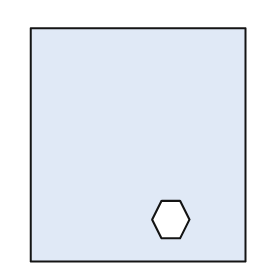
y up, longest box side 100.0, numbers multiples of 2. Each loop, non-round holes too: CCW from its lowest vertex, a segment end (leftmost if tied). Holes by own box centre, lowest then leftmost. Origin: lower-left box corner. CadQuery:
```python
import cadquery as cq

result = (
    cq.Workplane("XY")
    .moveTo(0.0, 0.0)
    .lineTo(92.0, 0.0)
    .lineTo(92.0, 100.0)
    .lineTo(0.0, 100.0)
    .close()
    .moveTo(56.0, 10.0)
    .lineTo(64.0, 10.0)
    .lineTo(68.0, 18.0)
    .lineTo(64.0, 26.0)
    .lineTo(56.0, 26.0)
    .lineTo(52.0, 18.0)
    .close()
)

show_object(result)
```